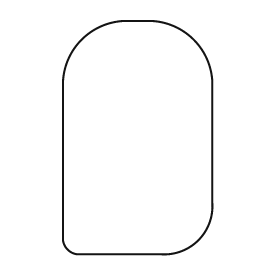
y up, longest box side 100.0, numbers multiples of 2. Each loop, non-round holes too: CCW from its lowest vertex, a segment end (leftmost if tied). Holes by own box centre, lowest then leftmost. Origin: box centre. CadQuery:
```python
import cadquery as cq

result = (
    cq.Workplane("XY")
    .moveTo(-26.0, -50.0)
    .lineTo(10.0, -50.0)
    .threePointArc((26.0, -44.0), (32.0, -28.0))
    .lineTo(32.0, 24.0)
    .threePointArc((24.0, 42.0), (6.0, 50.0))
    .lineTo(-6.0, 50.0)
    .threePointArc((-24.0, 42.0), (-32.0, 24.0))
    .lineTo(-32.0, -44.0)
    .threePointArc((-30.0, -48.0), (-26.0, -50.0))
    .close()
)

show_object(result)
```